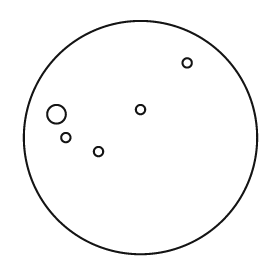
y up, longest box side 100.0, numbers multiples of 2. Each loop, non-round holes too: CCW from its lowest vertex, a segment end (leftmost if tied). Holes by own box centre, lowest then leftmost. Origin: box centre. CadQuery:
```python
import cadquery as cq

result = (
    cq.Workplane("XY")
    .moveTo(0.0, 0.0)
    .circle(50.0)
    .moveTo(-18.0, -6.0)
    .circle(2.0)
    .moveTo(-32.0, 0.0)
    .circle(2.0)
    .moveTo(-36.0, 10.0)
    .circle(4.0)
    .moveTo(0.0, 12.0)
    .circle(2.0)
    .moveTo(20.0, 32.0)
    .circle(2.0)
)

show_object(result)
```